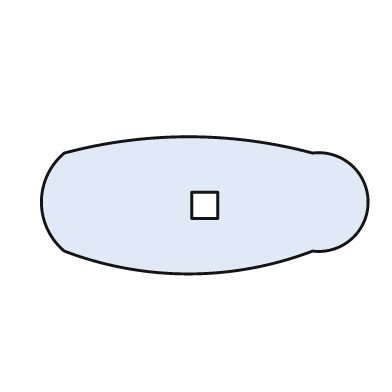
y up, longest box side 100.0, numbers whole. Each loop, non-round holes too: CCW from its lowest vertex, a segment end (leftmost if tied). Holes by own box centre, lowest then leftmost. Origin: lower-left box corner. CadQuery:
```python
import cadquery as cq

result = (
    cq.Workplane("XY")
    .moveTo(7.0, 7.0)
    .threePointArc((45.0, 0.0), (83.0, 7.0))
    .threePointArc((100.0, 22.0), (83.0, 37.0))
    .threePointArc((45.0, 42.0), (7.0, 37.0))
    .threePointArc((0.0, 22.0), (7.0, 7.0))
    .close()
    .moveTo(46.0, 17.0)
    .lineTo(54.0, 17.0)
    .lineTo(54.0, 25.0)
    .lineTo(46.0, 25.0)
    .close()
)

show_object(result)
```